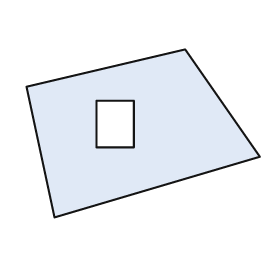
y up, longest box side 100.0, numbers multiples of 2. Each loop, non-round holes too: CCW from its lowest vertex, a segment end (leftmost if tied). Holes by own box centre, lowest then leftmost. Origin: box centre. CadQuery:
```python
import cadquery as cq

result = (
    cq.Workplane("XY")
    .moveTo(-38.0, -36.0)
    .lineTo(50.0, -10.0)
    .lineTo(18.0, 36.0)
    .lineTo(-50.0, 20.0)
    .close()
    .moveTo(-20.0, -6.0)
    .lineTo(-4.0, -6.0)
    .lineTo(-4.0, 14.0)
    .lineTo(-20.0, 14.0)
    .close()
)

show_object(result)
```